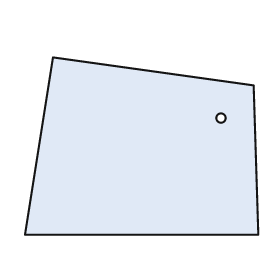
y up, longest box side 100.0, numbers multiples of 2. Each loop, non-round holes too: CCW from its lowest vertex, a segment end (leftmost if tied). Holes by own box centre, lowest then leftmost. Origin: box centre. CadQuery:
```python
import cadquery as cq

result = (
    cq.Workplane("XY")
    .moveTo(-50.0, -38.0)
    .lineTo(50.0, -38.0)
    .lineTo(48.0, 26.0)
    .lineTo(-38.0, 38.0)
    .close()
    .moveTo(34.0, 12.0)
    .circle(2.0)
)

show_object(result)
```